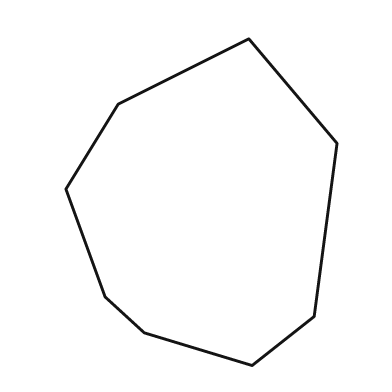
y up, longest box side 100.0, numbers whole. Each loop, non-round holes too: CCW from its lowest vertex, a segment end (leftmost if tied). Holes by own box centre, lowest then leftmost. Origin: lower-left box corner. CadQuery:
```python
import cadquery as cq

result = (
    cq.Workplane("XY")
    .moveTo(57.0, 0.0)
    .lineTo(76.0, 15.0)
    .lineTo(83.0, 68.0)
    .lineTo(56.0, 100.0)
    .lineTo(16.0, 80.0)
    .lineTo(0.0, 54.0)
    .lineTo(12.0, 21.0)
    .lineTo(24.0, 10.0)
    .close()
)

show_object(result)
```